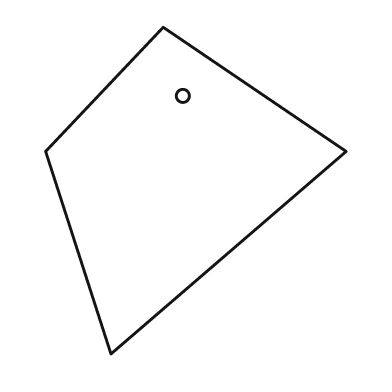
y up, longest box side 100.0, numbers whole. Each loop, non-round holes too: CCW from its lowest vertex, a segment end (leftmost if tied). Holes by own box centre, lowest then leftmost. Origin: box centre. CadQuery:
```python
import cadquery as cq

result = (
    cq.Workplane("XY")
    .moveTo(-26.0, -50.0)
    .lineTo(46.0, 12.0)
    .lineTo(-10.0, 50.0)
    .lineTo(-46.0, 12.0)
    .close()
    .moveTo(-4.0, 29.0)
    .circle(2.0)
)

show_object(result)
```